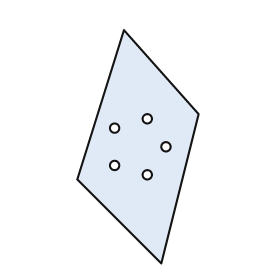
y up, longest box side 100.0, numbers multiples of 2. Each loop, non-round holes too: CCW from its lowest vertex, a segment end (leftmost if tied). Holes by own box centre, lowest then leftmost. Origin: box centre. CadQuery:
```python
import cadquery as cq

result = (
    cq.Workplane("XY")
    .moveTo(10.0, -50.0)
    .lineTo(26.0, 14.0)
    .lineTo(-6.0, 50.0)
    .lineTo(-26.0, -14.0)
    .close()
    .moveTo(4.0, -12.0)
    .circle(2.0)
    .moveTo(-10.0, -8.0)
    .circle(2.0)
    .moveTo(12.0, 0.0)
    .circle(2.0)
    .moveTo(-10.0, 8.0)
    .circle(2.0)
    .moveTo(4.0, 12.0)
    .circle(2.0)
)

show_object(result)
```